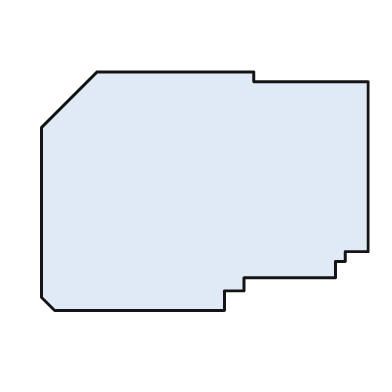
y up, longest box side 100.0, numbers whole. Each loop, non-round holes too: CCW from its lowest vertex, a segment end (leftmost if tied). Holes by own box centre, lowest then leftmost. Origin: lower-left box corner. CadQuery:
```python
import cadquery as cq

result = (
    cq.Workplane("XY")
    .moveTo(4.0, 0.0)
    .lineTo(56.0, 0.0)
    .lineTo(56.0, 6.0)
    .lineTo(62.0, 6.0)
    .lineTo(62.0, 10.0)
    .lineTo(90.0, 10.0)
    .lineTo(90.0, 15.0)
    .lineTo(93.0, 15.0)
    .lineTo(93.0, 18.0)
    .lineTo(100.0, 18.0)
    .lineTo(100.0, 70.0)
    .lineTo(65.0, 70.0)
    .lineTo(65.0, 73.0)
    .lineTo(17.0, 73.0)
    .lineTo(0.0, 56.0)
    .lineTo(0.0, 4.0)
    .close()
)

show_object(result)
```